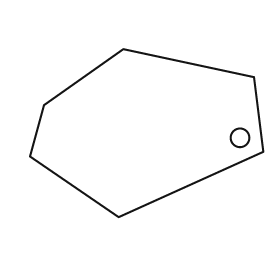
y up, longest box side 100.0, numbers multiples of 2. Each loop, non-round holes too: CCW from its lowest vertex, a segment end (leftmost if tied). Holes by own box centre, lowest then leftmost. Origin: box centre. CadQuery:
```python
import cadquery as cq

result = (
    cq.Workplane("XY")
    .moveTo(-12.0, -36.0)
    .lineTo(50.0, -8.0)
    .lineTo(46.0, 24.0)
    .lineTo(-10.0, 36.0)
    .lineTo(-44.0, 12.0)
    .lineTo(-50.0, -10.0)
    .close()
    .moveTo(40.0, -2.0)
    .circle(4.0)
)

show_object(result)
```